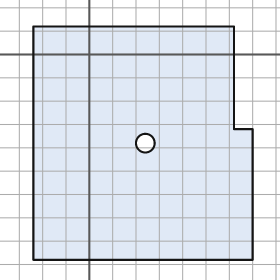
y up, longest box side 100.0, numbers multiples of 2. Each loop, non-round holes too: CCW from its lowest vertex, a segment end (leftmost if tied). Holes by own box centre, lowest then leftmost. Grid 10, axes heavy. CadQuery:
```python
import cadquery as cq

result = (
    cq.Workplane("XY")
    .moveTo(-24.0, -88.0)
    .lineTo(70.0, -88.0)
    .lineTo(70.0, -32.0)
    .lineTo(62.0, -32.0)
    .lineTo(62.0, 12.0)
    .lineTo(-24.0, 12.0)
    .close()
    .moveTo(24.0, -38.0)
    .circle(4.0)
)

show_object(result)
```